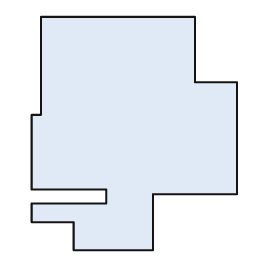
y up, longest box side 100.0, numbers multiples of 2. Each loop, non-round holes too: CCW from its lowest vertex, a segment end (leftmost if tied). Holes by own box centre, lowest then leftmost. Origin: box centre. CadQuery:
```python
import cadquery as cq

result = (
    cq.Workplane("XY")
    .moveTo(-26.0, -50.0)
    .lineTo(8.0, -50.0)
    .lineTo(8.0, -26.0)
    .lineTo(44.0, -26.0)
    .lineTo(44.0, 22.0)
    .lineTo(26.0, 22.0)
    .lineTo(26.0, 50.0)
    .lineTo(-40.0, 50.0)
    .lineTo(-40.0, 8.0)
    .lineTo(-44.0, 8.0)
    .lineTo(-44.0, -24.0)
    .lineTo(-12.0, -24.0)
    .lineTo(-12.0, -30.0)
    .lineTo(-44.0, -30.0)
    .lineTo(-44.0, -38.0)
    .lineTo(-26.0, -38.0)
    .close()
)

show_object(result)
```